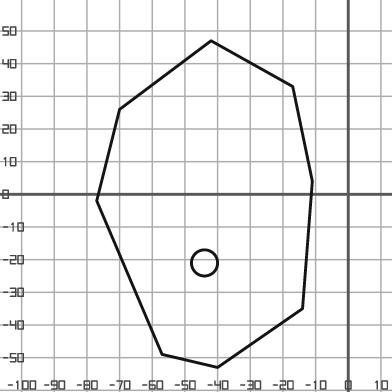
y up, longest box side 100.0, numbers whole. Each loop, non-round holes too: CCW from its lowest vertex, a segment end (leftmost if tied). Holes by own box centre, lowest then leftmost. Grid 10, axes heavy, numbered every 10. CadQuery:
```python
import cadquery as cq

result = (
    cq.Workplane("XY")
    .moveTo(-40.0, -53.0)
    .lineTo(-14.0, -35.0)
    .lineTo(-11.0, 4.0)
    .lineTo(-17.0, 33.0)
    .lineTo(-42.0, 47.0)
    .lineTo(-70.0, 26.0)
    .lineTo(-77.0, -2.0)
    .lineTo(-57.0, -49.0)
    .close()
    .moveTo(-44.0, -21.0)
    .circle(4.0)
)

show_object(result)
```